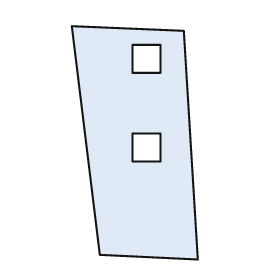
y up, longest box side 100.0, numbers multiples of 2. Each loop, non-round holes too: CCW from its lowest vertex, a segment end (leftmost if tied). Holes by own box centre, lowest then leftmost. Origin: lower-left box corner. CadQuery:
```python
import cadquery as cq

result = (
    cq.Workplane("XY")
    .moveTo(54.0, 0.0)
    .lineTo(48.0, 98.0)
    .lineTo(0.0, 100.0)
    .lineTo(12.0, 2.0)
    .close()
    .moveTo(26.0, 42.0)
    .lineTo(38.0, 42.0)
    .lineTo(38.0, 54.0)
    .lineTo(26.0, 54.0)
    .close()
    .moveTo(26.0, 80.0)
    .lineTo(38.0, 80.0)
    .lineTo(38.0, 92.0)
    .lineTo(26.0, 92.0)
    .close()
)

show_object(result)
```